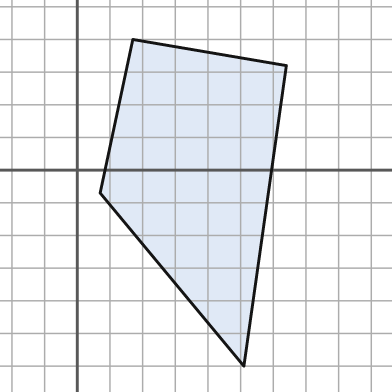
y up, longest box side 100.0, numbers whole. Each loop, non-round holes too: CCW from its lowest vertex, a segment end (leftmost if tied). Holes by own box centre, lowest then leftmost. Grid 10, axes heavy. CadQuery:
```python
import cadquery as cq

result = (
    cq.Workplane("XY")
    .moveTo(51.0, -60.0)
    .lineTo(64.0, 32.0)
    .lineTo(17.0, 40.0)
    .lineTo(7.0, -7.0)
    .close()
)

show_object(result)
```